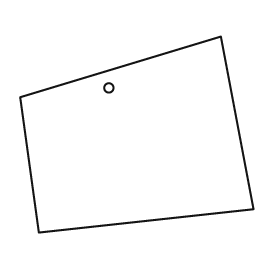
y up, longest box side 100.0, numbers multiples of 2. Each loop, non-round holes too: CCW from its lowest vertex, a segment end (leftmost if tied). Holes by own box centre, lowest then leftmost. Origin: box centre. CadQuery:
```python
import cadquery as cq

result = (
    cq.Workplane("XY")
    .moveTo(-42.0, -42.0)
    .lineTo(50.0, -32.0)
    .lineTo(36.0, 42.0)
    .lineTo(-50.0, 16.0)
    .close()
    .moveTo(-12.0, 20.0)
    .circle(2.0)
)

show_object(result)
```